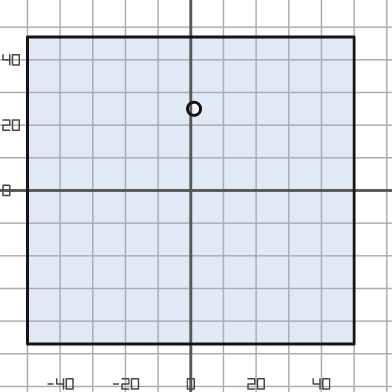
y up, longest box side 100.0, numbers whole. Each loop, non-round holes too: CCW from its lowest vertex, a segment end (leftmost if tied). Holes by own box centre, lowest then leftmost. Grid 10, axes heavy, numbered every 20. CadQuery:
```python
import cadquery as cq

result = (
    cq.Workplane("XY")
    .moveTo(-50.0, -47.0)
    .lineTo(50.0, -47.0)
    .lineTo(50.0, 47.0)
    .lineTo(-50.0, 47.0)
    .close()
    .moveTo(1.0, 25.0)
    .circle(2.0)
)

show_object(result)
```